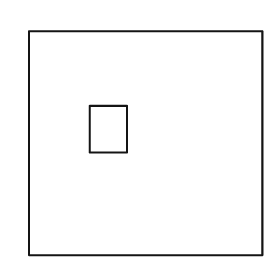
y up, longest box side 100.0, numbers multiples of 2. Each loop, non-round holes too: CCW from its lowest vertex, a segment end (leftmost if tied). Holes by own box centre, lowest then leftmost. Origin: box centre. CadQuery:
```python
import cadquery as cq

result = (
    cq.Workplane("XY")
    .moveTo(-50.0, -48.0)
    .lineTo(50.0, -48.0)
    .lineTo(50.0, 48.0)
    .lineTo(-50.0, 48.0)
    .close()
    .moveTo(-24.0, -4.0)
    .lineTo(-8.0, -4.0)
    .lineTo(-8.0, 16.0)
    .lineTo(-24.0, 16.0)
    .close()
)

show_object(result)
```